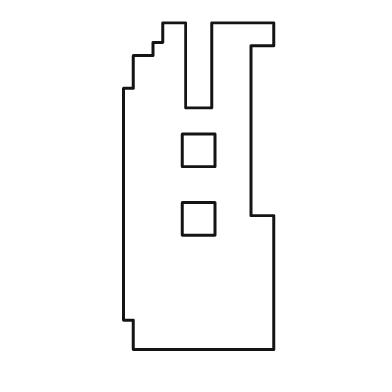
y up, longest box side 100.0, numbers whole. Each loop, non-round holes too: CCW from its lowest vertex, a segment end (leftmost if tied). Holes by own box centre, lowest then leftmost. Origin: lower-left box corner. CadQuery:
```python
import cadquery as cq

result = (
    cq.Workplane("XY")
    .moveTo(3.0, 0.0)
    .lineTo(46.0, 0.0)
    .lineTo(46.0, 41.0)
    .lineTo(39.0, 41.0)
    .lineTo(39.0, 93.0)
    .lineTo(46.0, 93.0)
    .lineTo(46.0, 100.0)
    .lineTo(27.0, 100.0)
    .lineTo(27.0, 74.0)
    .lineTo(19.0, 74.0)
    .lineTo(19.0, 100.0)
    .lineTo(12.0, 100.0)
    .lineTo(12.0, 94.0)
    .lineTo(9.0, 94.0)
    .lineTo(9.0, 90.0)
    .lineTo(3.0, 90.0)
    .lineTo(3.0, 80.0)
    .lineTo(0.0, 80.0)
    .lineTo(0.0, 9.0)
    .lineTo(3.0, 9.0)
    .close()
    .moveTo(18.0, 35.0)
    .lineTo(28.0, 35.0)
    .lineTo(28.0, 45.0)
    .lineTo(18.0, 45.0)
    .close()
    .moveTo(18.0, 56.0)
    .lineTo(28.0, 56.0)
    .lineTo(28.0, 66.0)
    .lineTo(18.0, 66.0)
    .close()
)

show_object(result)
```